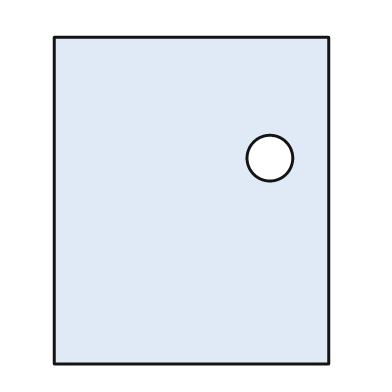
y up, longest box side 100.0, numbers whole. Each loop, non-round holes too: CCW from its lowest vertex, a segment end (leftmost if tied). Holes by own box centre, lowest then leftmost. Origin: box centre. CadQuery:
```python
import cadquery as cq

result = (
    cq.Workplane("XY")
    .moveTo(-42.0, -50.0)
    .lineTo(42.0, -50.0)
    .lineTo(42.0, 50.0)
    .lineTo(-42.0, 50.0)
    .close()
    .moveTo(24.0, 13.0)
    .circle(7.0)
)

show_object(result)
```